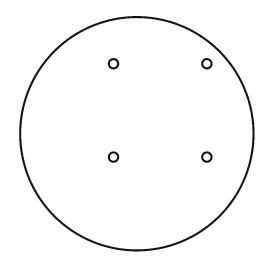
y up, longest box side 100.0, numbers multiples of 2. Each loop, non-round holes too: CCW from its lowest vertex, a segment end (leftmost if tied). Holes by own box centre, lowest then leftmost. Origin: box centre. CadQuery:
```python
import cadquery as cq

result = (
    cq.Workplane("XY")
    .moveTo(0.0, 0.0)
    .circle(50.0)
    .moveTo(-10.0, -10.0)
    .circle(2.0)
    .moveTo(30.0, -10.0)
    .circle(2.0)
    .moveTo(-10.0, 30.0)
    .circle(2.0)
    .moveTo(30.0, 30.0)
    .circle(2.0)
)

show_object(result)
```